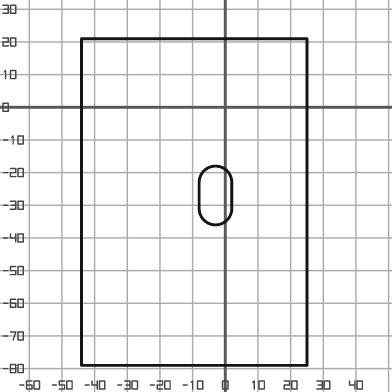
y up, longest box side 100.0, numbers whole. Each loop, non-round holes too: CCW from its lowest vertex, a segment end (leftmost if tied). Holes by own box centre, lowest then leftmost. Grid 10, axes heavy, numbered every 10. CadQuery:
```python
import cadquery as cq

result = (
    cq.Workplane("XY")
    .moveTo(-44.0, -79.0)
    .lineTo(25.0, -79.0)
    .lineTo(25.0, 21.0)
    .lineTo(-44.0, 21.0)
    .close()
    .moveTo(-8.0, -31.0)
    .threePointArc((-3.0, -36.0), (2.0, -31.0))
    .lineTo(2.0, -23.0)
    .threePointArc((-3.0, -18.0), (-8.0, -23.0))
    .close()
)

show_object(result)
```